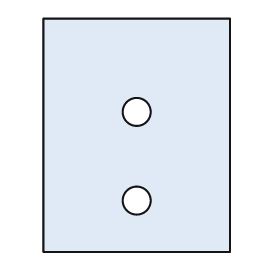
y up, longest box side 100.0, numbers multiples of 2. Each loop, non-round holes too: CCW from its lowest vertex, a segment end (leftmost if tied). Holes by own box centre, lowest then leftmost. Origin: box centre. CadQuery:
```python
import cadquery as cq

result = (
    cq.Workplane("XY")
    .moveTo(-40.0, -50.0)
    .lineTo(40.0, -50.0)
    .lineTo(40.0, 50.0)
    .lineTo(-40.0, 50.0)
    .close()
    .moveTo(0.0, -28.0)
    .circle(6.0)
    .moveTo(0.0, 10.0)
    .circle(6.0)
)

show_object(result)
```